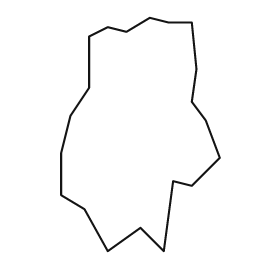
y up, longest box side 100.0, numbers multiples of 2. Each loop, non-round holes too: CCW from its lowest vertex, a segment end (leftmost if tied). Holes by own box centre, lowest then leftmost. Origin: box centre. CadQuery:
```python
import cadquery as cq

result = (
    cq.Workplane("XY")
    .moveTo(-14.0, -50.0)
    .lineTo(0.0, -40.0)
    .lineTo(10.0, -50.0)
    .lineTo(14.0, -20.0)
    .lineTo(22.0, -22.0)
    .lineTo(34.0, -10.0)
    .lineTo(28.0, 6.0)
    .lineTo(22.0, 14.0)
    .lineTo(24.0, 28.0)
    .lineTo(22.0, 48.0)
    .lineTo(12.0, 48.0)
    .lineTo(4.0, 50.0)
    .lineTo(-6.0, 44.0)
    .lineTo(-14.0, 46.0)
    .lineTo(-22.0, 42.0)
    .lineTo(-22.0, 20.0)
    .lineTo(-30.0, 8.0)
    .lineTo(-34.0, -8.0)
    .lineTo(-34.0, -26.0)
    .lineTo(-24.0, -32.0)
    .close()
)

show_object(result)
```